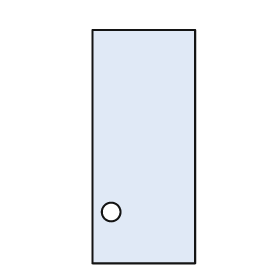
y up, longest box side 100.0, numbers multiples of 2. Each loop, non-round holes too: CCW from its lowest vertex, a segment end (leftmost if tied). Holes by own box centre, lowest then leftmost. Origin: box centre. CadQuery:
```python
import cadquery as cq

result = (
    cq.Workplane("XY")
    .moveTo(-22.0, -50.0)
    .lineTo(22.0, -50.0)
    .lineTo(22.0, 50.0)
    .lineTo(-22.0, 50.0)
    .close()
    .moveTo(-14.0, -28.0)
    .circle(4.0)
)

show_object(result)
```